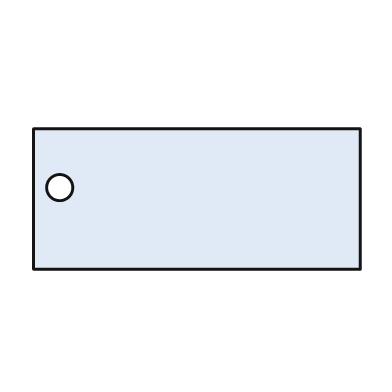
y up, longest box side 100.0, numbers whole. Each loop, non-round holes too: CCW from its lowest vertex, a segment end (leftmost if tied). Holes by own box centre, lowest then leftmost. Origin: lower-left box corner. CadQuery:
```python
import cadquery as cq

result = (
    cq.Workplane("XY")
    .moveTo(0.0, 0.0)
    .lineTo(100.0, 0.0)
    .lineTo(100.0, 43.0)
    .lineTo(0.0, 43.0)
    .close()
    .moveTo(8.0, 25.0)
    .circle(4.0)
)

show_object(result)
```